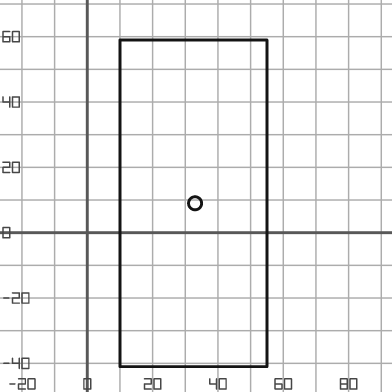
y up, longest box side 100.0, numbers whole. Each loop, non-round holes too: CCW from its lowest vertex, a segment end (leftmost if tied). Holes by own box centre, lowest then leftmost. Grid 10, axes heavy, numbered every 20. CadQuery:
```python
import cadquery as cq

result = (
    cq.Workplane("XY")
    .moveTo(10.0, -41.0)
    .lineTo(55.0, -41.0)
    .lineTo(55.0, 59.0)
    .lineTo(10.0, 59.0)
    .close()
    .moveTo(33.0, 9.0)
    .circle(2.0)
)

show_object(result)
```